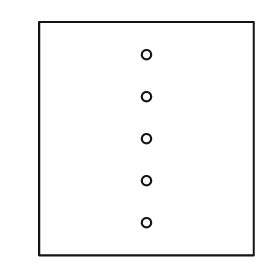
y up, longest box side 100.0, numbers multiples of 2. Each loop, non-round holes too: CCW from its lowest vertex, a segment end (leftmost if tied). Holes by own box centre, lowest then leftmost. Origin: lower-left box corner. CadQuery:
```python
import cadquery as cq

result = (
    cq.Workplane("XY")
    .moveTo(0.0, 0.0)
    .lineTo(92.0, 0.0)
    .lineTo(92.0, 100.0)
    .lineTo(0.0, 100.0)
    .close()
    .moveTo(46.0, 14.0)
    .circle(2.0)
    .moveTo(46.0, 32.0)
    .circle(2.0)
    .moveTo(46.0, 50.0)
    .circle(2.0)
    .moveTo(46.0, 68.0)
    .circle(2.0)
    .moveTo(46.0, 86.0)
    .circle(2.0)
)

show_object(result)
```